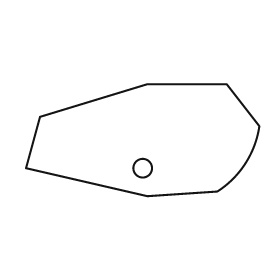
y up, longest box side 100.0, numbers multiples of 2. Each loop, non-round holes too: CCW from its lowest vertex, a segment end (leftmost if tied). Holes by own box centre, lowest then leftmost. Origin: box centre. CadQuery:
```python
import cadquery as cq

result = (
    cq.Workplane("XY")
    .moveTo(2.0, -24.0)
    .lineTo(32.0, -22.0)
    .threePointArc((44.0, -10.0), (50.0, 6.0))
    .lineTo(36.0, 24.0)
    .lineTo(2.0, 24.0)
    .lineTo(-44.0, 10.0)
    .lineTo(-50.0, -12.0)
    .close()
    .moveTo(0.0, -12.0)
    .circle(4.0)
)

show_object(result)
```